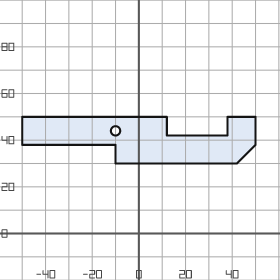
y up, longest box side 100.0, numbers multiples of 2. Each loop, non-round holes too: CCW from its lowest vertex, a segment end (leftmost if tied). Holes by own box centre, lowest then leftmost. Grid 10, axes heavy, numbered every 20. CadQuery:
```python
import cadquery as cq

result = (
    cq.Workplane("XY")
    .moveTo(-10.0, 30.0)
    .lineTo(42.0, 30.0)
    .lineTo(50.0, 38.0)
    .lineTo(50.0, 50.0)
    .lineTo(38.0, 50.0)
    .lineTo(38.0, 42.0)
    .lineTo(12.0, 42.0)
    .lineTo(12.0, 50.0)
    .lineTo(-50.0, 50.0)
    .lineTo(-50.0, 38.0)
    .lineTo(-10.0, 38.0)
    .close()
    .moveTo(-10.0, 44.0)
    .circle(2.0)
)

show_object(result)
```